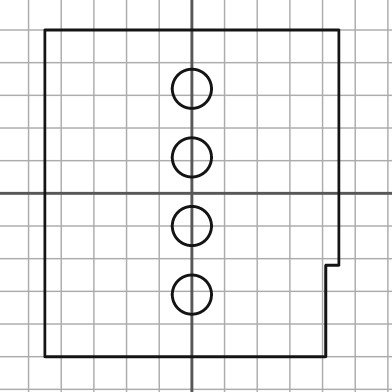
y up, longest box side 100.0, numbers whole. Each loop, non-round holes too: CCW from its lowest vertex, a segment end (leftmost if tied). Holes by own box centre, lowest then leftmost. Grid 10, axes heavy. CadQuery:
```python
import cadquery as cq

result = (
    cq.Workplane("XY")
    .moveTo(-45.0, -50.0)
    .lineTo(41.0, -50.0)
    .lineTo(41.0, -22.0)
    .lineTo(45.0, -22.0)
    .lineTo(45.0, 50.0)
    .lineTo(-45.0, 50.0)
    .close()
    .moveTo(0.0, -31.0)
    .circle(6.0)
    .moveTo(0.0, -10.0)
    .circle(6.0)
    .moveTo(0.0, 11.0)
    .circle(6.0)
    .moveTo(0.0, 32.0)
    .circle(6.0)
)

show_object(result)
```